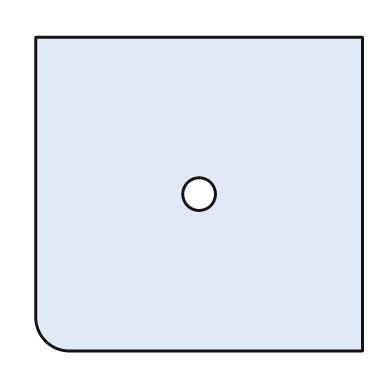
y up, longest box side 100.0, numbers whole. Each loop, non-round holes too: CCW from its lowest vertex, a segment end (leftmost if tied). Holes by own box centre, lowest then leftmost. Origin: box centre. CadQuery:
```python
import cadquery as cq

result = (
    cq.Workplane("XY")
    .moveTo(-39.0, -48.0)
    .lineTo(50.0, -48.0)
    .lineTo(50.0, 48.0)
    .lineTo(-50.0, 48.0)
    .lineTo(-50.0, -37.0)
    .threePointArc((-47.0, -45.0), (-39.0, -48.0))
    .close()
    .moveTo(0.0, 0.0)
    .circle(5.0)
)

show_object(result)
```